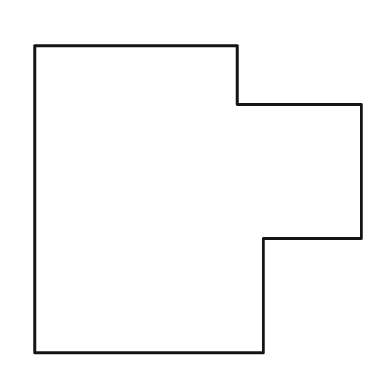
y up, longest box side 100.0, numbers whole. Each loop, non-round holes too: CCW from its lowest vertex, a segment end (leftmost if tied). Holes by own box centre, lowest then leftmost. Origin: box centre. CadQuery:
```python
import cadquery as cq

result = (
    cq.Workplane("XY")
    .moveTo(-50.0, -47.0)
    .lineTo(20.0, -47.0)
    .lineTo(20.0, -12.0)
    .lineTo(50.0, -12.0)
    .lineTo(50.0, 29.0)
    .lineTo(12.0, 29.0)
    .lineTo(12.0, 47.0)
    .lineTo(-50.0, 47.0)
    .close()
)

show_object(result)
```